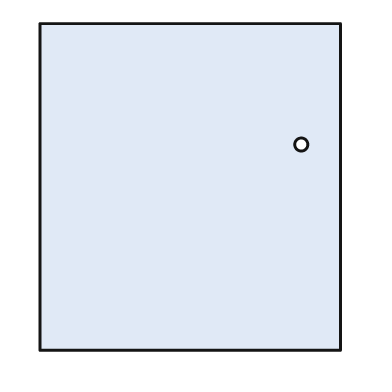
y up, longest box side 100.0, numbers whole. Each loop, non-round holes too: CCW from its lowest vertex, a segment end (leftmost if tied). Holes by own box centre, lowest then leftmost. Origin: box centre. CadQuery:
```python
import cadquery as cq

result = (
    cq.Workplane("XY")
    .moveTo(-46.0, -50.0)
    .lineTo(46.0, -50.0)
    .lineTo(46.0, 50.0)
    .lineTo(-46.0, 50.0)
    .close()
    .moveTo(34.0, 13.0)
    .circle(2.0)
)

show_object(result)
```